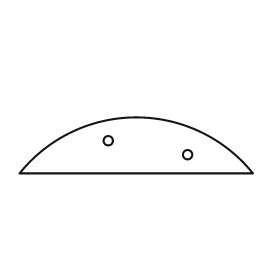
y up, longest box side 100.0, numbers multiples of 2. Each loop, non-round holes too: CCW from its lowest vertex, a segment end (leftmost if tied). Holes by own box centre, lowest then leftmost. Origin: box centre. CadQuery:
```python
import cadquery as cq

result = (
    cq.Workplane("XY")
    .moveTo(-50.0, -12.0)
    .lineTo(50.0, -12.0)
    .threePointArc((0.0, 12.0), (-50.0, -12.0))
    .close()
    .moveTo(22.0, -4.0)
    .circle(2.0)
    .moveTo(-12.0, 2.0)
    .circle(2.0)
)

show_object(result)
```